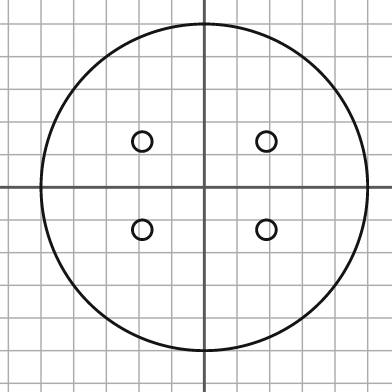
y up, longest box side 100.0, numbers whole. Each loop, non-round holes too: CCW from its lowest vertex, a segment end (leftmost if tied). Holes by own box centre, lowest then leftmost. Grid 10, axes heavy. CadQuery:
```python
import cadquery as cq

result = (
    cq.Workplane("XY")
    .moveTo(0.0, 0.0)
    .circle(50.0)
    .moveTo(-19.0, -13.0)
    .circle(3.0)
    .moveTo(19.0, -13.0)
    .circle(3.0)
    .moveTo(-19.0, 14.0)
    .circle(3.0)
    .moveTo(19.0, 14.0)
    .circle(3.0)
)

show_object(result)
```